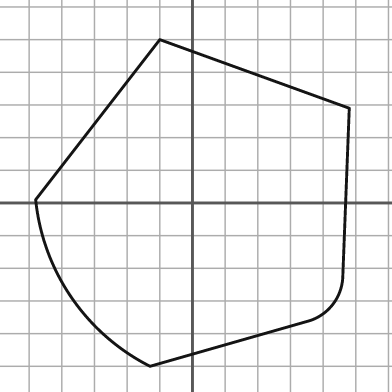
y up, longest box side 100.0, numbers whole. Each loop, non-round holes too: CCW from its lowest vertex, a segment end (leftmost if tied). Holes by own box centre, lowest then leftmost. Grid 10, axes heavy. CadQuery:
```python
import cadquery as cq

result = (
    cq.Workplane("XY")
    .moveTo(-13.0, -50.0)
    .lineTo(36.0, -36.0)
    .threePointArc((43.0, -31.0), (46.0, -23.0))
    .lineTo(48.0, 29.0)
    .lineTo(-10.0, 50.0)
    .lineTo(-48.0, 1.0)
    .threePointArc((-37.0, -29.0), (-13.0, -50.0))
    .close()
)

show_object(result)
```